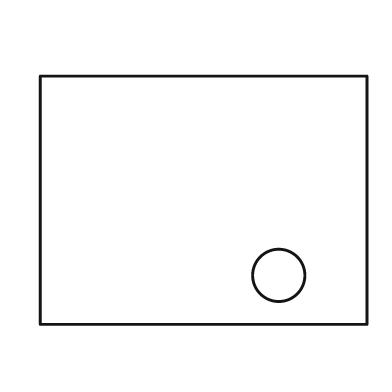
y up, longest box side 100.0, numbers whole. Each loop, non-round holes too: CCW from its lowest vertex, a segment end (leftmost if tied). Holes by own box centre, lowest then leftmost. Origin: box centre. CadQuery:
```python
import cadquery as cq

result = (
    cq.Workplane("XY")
    .moveTo(-50.0, -38.0)
    .lineTo(50.0, -38.0)
    .lineTo(50.0, 38.0)
    .lineTo(-50.0, 38.0)
    .close()
    .moveTo(23.0, -23.0)
    .circle(8.0)
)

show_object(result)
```